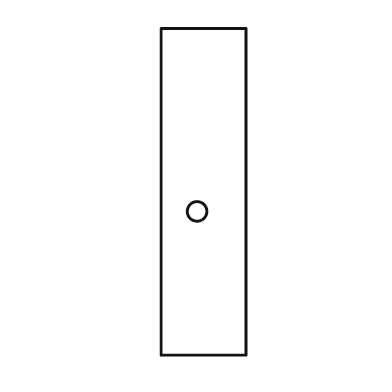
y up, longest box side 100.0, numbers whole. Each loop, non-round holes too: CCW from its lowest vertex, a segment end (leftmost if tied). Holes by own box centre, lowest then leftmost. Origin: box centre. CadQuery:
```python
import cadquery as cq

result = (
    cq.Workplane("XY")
    .moveTo(-13.0, -50.0)
    .lineTo(13.0, -50.0)
    .lineTo(13.0, 50.0)
    .lineTo(-13.0, 50.0)
    .close()
    .moveTo(-2.0, -6.0)
    .circle(3.0)
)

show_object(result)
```